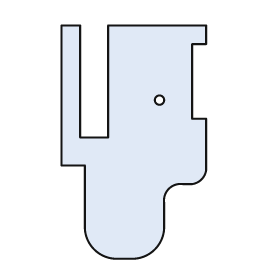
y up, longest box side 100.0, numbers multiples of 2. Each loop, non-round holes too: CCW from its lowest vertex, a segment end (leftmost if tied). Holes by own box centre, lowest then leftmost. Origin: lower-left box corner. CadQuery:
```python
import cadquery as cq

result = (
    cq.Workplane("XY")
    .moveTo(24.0, 0.0)
    .lineTo(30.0, 0.0)
    .threePointArc((40.0, 4.0), (44.0, 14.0))
    .lineTo(44.0, 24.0)
    .threePointArc((46.0, 30.0), (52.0, 32.0))
    .lineTo(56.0, 32.0)
    .threePointArc((60.0, 34.0), (62.0, 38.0))
    .lineTo(62.0, 60.0)
    .lineTo(56.0, 60.0)
    .lineTo(56.0, 92.0)
    .lineTo(62.0, 92.0)
    .lineTo(62.0, 100.0)
    .lineTo(20.0, 100.0)
    .lineTo(20.0, 52.0)
    .lineTo(8.0, 52.0)
    .lineTo(8.0, 100.0)
    .lineTo(0.0, 100.0)
    .lineTo(0.0, 40.0)
    .lineTo(10.0, 40.0)
    .lineTo(10.0, 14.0)
    .threePointArc((14.0, 4.0), (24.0, 0.0))
    .close()
    .moveTo(42.0, 68.0)
    .circle(2.0)
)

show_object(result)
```